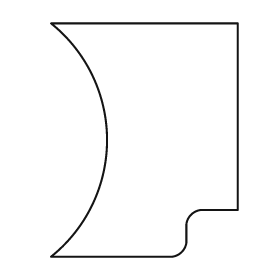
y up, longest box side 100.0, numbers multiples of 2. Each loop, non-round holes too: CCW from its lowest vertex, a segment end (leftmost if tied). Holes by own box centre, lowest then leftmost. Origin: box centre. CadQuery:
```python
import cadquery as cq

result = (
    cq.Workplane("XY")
    .moveTo(-40.0, -50.0)
    .lineTo(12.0, -50.0)
    .threePointArc((16.0, -48.0), (18.0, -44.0))
    .lineTo(18.0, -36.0)
    .threePointArc((20.0, -32.0), (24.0, -30.0))
    .lineTo(40.0, -30.0)
    .lineTo(40.0, 50.0)
    .lineTo(-40.0, 50.0)
    .threePointArc((-16.0, 0.0), (-40.0, -50.0))
    .close()
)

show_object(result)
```